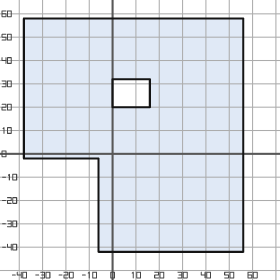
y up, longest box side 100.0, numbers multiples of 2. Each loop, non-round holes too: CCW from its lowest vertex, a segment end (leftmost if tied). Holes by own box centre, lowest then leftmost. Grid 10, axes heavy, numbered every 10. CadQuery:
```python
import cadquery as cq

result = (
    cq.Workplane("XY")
    .moveTo(-6.0, -42.0)
    .lineTo(56.0, -42.0)
    .lineTo(56.0, 58.0)
    .lineTo(-38.0, 58.0)
    .lineTo(-38.0, -2.0)
    .lineTo(-6.0, -2.0)
    .close()
    .moveTo(0.0, 20.0)
    .lineTo(16.0, 20.0)
    .lineTo(16.0, 32.0)
    .lineTo(0.0, 32.0)
    .close()
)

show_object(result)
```